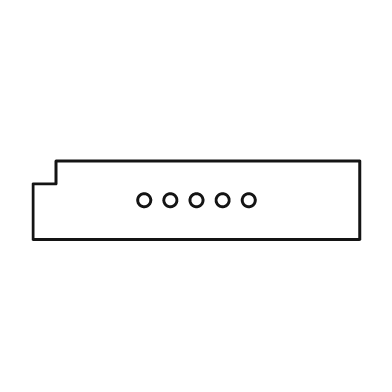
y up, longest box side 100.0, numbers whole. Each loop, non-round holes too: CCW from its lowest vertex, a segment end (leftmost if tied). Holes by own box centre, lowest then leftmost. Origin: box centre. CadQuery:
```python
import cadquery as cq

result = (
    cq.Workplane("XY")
    .moveTo(-50.0, -12.0)
    .lineTo(50.0, -12.0)
    .lineTo(50.0, 12.0)
    .lineTo(-43.0, 12.0)
    .lineTo(-43.0, 5.0)
    .lineTo(-50.0, 5.0)
    .close()
    .moveTo(-16.0, 0.0)
    .circle(2.0)
    .moveTo(-8.0, 0.0)
    .circle(2.0)
    .moveTo(0.0, 0.0)
    .circle(2.0)
    .moveTo(8.0, 0.0)
    .circle(2.0)
    .moveTo(16.0, 0.0)
    .circle(2.0)
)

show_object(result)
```